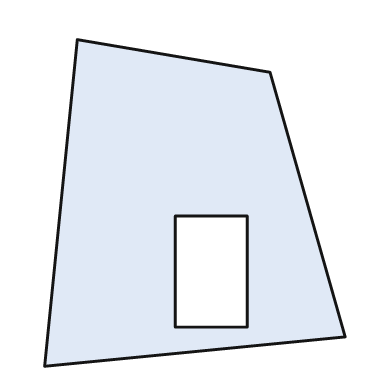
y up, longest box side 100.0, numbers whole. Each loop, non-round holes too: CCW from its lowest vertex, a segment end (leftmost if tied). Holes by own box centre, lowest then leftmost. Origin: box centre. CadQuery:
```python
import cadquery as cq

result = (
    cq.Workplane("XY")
    .moveTo(-46.0, -50.0)
    .lineTo(46.0, -41.0)
    .lineTo(23.0, 40.0)
    .lineTo(-36.0, 50.0)
    .close()
    .moveTo(-6.0, -38.0)
    .lineTo(16.0, -38.0)
    .lineTo(16.0, -4.0)
    .lineTo(-6.0, -4.0)
    .close()
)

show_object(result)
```